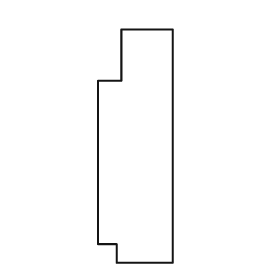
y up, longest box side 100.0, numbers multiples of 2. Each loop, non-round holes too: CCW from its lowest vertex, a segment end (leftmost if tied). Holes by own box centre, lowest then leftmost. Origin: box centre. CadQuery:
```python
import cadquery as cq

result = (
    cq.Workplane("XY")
    .moveTo(-8.0, -50.0)
    .lineTo(16.0, -50.0)
    .lineTo(16.0, 50.0)
    .lineTo(-6.0, 50.0)
    .lineTo(-6.0, 28.0)
    .lineTo(-16.0, 28.0)
    .lineTo(-16.0, -42.0)
    .lineTo(-8.0, -42.0)
    .close()
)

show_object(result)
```